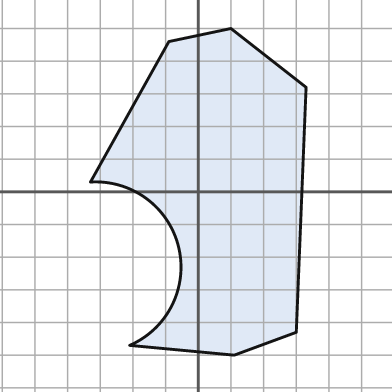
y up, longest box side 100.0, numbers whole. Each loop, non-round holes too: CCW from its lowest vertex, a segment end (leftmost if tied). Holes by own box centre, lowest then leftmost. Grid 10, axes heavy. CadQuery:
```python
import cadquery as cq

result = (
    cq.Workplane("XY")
    .moveTo(11.0, -50.0)
    .lineTo(30.0, -43.0)
    .lineTo(33.0, 32.0)
    .lineTo(10.0, 50.0)
    .lineTo(-9.0, 46.0)
    .lineTo(-33.0, 3.0)
    .threePointArc((-6.0, -17.0), (-21.0, -47.0))
    .close()
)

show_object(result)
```